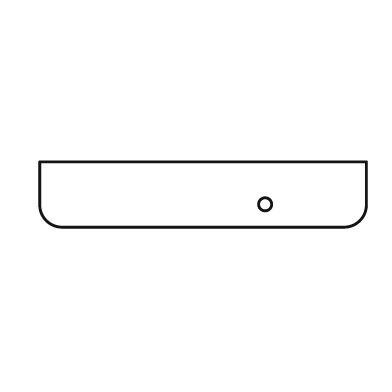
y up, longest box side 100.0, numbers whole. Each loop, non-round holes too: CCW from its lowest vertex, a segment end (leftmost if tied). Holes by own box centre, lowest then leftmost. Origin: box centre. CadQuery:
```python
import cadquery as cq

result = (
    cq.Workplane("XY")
    .moveTo(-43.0, -10.0)
    .lineTo(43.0, -10.0)
    .threePointArc((48.0, -8.0), (50.0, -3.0))
    .lineTo(50.0, 10.0)
    .lineTo(-50.0, 10.0)
    .lineTo(-50.0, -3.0)
    .threePointArc((-48.0, -8.0), (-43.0, -10.0))
    .close()
    .moveTo(19.0, -3.0)
    .circle(2.0)
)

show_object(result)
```